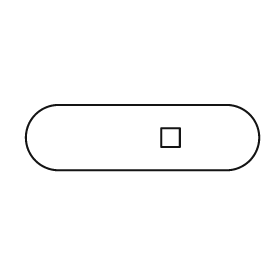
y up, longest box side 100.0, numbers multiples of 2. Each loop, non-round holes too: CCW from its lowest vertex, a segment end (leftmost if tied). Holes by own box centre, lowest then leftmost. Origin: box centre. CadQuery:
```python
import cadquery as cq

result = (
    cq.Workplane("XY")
    .moveTo(-36.0, -14.0)
    .lineTo(36.0, -14.0)
    .threePointArc((50.0, 0.0), (36.0, 14.0))
    .lineTo(-36.0, 14.0)
    .threePointArc((-50.0, 0.0), (-36.0, -14.0))
    .close()
    .moveTo(8.0, -4.0)
    .lineTo(16.0, -4.0)
    .lineTo(16.0, 4.0)
    .lineTo(8.0, 4.0)
    .close()
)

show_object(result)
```